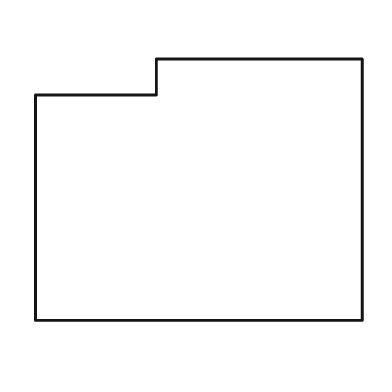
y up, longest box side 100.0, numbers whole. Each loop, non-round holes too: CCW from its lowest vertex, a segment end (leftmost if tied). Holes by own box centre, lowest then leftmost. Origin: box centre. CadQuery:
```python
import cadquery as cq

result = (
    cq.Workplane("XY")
    .moveTo(-50.0, -40.0)
    .lineTo(50.0, -40.0)
    .lineTo(50.0, 40.0)
    .lineTo(-13.0, 40.0)
    .lineTo(-13.0, 29.0)
    .lineTo(-50.0, 29.0)
    .close()
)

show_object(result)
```